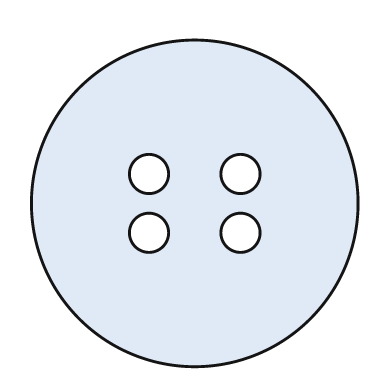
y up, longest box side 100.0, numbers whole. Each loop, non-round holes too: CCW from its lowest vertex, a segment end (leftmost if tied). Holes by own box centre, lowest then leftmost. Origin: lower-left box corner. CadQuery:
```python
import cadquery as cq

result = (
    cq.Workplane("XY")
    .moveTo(50.0, 50.0)
    .circle(50.0)
    .moveTo(36.0, 41.0)
    .circle(6.0)
    .moveTo(64.0, 41.0)
    .circle(6.0)
    .moveTo(36.0, 59.0)
    .circle(6.0)
    .moveTo(64.0, 59.0)
    .circle(6.0)
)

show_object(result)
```